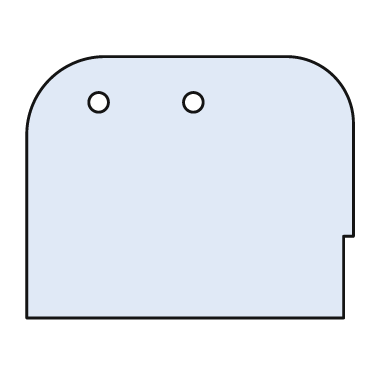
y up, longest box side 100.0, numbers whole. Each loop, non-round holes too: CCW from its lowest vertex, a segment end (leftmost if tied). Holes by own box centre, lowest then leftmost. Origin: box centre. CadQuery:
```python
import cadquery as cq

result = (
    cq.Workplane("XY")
    .moveTo(-50.0, -40.0)
    .lineTo(47.0, -40.0)
    .lineTo(47.0, -15.0)
    .lineTo(50.0, -15.0)
    .lineTo(50.0, 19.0)
    .threePointArc((44.0, 34.0), (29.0, 40.0))
    .lineTo(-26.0, 40.0)
    .threePointArc((-43.0, 33.0), (-50.0, 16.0))
    .close()
    .moveTo(-28.0, 26.0)
    .circle(3.0)
    .moveTo(1.0, 26.0)
    .circle(3.0)
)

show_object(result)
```